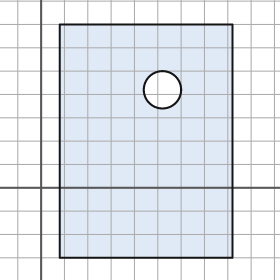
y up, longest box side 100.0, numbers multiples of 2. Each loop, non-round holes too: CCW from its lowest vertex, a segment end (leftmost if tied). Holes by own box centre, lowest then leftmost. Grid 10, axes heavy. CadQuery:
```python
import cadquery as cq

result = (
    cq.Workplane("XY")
    .moveTo(8.0, -30.0)
    .lineTo(82.0, -30.0)
    .lineTo(82.0, 70.0)
    .lineTo(8.0, 70.0)
    .close()
    .moveTo(52.0, 42.0)
    .circle(8.0)
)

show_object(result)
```